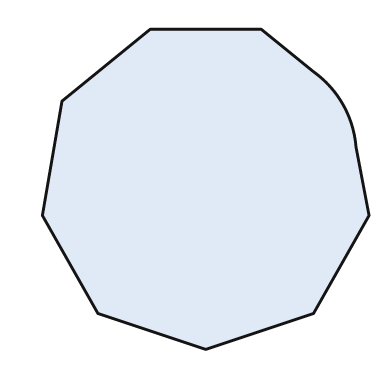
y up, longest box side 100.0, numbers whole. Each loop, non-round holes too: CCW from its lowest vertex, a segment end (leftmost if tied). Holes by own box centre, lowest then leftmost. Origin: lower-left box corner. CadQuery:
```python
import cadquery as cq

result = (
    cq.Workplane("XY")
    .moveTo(50.0, 0.0)
    .lineTo(83.0, 11.0)
    .lineTo(100.0, 41.0)
    .lineTo(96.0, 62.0)
    .threePointArc((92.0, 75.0), (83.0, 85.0))
    .lineTo(67.0, 98.0)
    .lineTo(33.0, 98.0)
    .lineTo(6.0, 76.0)
    .lineTo(0.0, 41.0)
    .lineTo(17.0, 11.0)
    .close()
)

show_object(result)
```